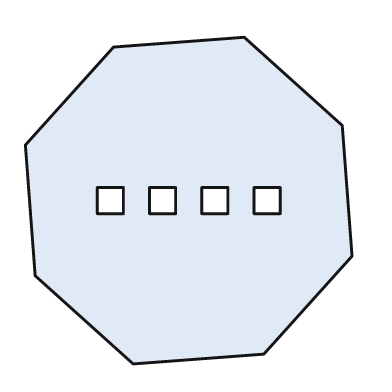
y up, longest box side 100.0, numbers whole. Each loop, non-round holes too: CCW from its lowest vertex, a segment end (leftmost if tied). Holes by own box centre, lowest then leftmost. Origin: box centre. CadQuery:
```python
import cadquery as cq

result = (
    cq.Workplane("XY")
    .moveTo(-17.0, -50.0)
    .lineTo(23.0, -47.0)
    .lineTo(50.0, -17.0)
    .lineTo(47.0, 23.0)
    .lineTo(17.0, 50.0)
    .lineTo(-23.0, 47.0)
    .lineTo(-50.0, 17.0)
    .lineTo(-47.0, -23.0)
    .close()
    .moveTo(-28.0, -4.0)
    .lineTo(-20.0, -4.0)
    .lineTo(-20.0, 4.0)
    .lineTo(-28.0, 4.0)
    .close()
    .moveTo(-12.0, -4.0)
    .lineTo(-4.0, -4.0)
    .lineTo(-4.0, 4.0)
    .lineTo(-12.0, 4.0)
    .close()
    .moveTo(4.0, -4.0)
    .lineTo(12.0, -4.0)
    .lineTo(12.0, 4.0)
    .lineTo(4.0, 4.0)
    .close()
    .moveTo(20.0, -4.0)
    .lineTo(28.0, -4.0)
    .lineTo(28.0, 4.0)
    .lineTo(20.0, 4.0)
    .close()
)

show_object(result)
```